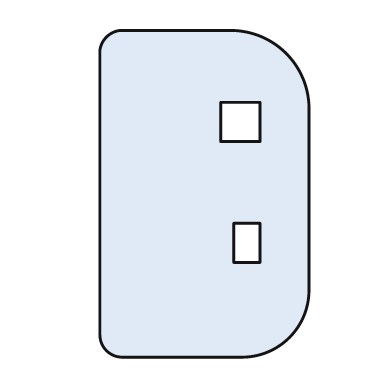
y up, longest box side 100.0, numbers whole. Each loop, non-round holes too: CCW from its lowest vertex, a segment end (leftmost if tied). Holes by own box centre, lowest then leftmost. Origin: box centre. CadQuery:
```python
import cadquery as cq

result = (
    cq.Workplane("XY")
    .moveTo(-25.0, -50.0)
    .lineTo(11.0, -50.0)
    .threePointArc((26.0, -44.0), (32.0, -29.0))
    .lineTo(32.0, 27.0)
    .threePointArc((25.0, 43.0), (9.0, 50.0))
    .lineTo(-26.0, 50.0)
    .threePointArc((-30.0, 48.0), (-32.0, 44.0))
    .lineTo(-32.0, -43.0)
    .threePointArc((-30.0, -48.0), (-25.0, -50.0))
    .close()
    .moveTo(9.0, -21.0)
    .lineTo(17.0, -21.0)
    .lineTo(17.0, -9.0)
    .lineTo(9.0, -9.0)
    .close()
    .moveTo(5.0, 16.0)
    .lineTo(17.0, 16.0)
    .lineTo(17.0, 28.0)
    .lineTo(5.0, 28.0)
    .close()
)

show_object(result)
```